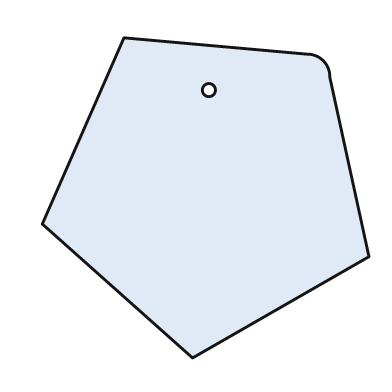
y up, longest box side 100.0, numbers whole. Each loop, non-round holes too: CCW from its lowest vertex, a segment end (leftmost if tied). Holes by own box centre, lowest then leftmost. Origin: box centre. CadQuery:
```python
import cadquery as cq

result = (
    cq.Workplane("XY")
    .moveTo(-4.0, -49.0)
    .lineTo(50.0, -18.0)
    .lineTo(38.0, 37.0)
    .threePointArc((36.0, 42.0), (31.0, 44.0))
    .lineTo(-25.0, 49.0)
    .lineTo(-50.0, -8.0)
    .close()
    .moveTo(1.0, 33.0)
    .circle(2.0)
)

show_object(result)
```